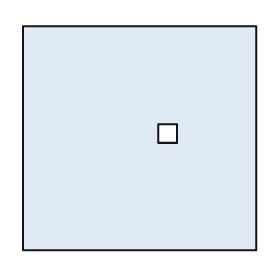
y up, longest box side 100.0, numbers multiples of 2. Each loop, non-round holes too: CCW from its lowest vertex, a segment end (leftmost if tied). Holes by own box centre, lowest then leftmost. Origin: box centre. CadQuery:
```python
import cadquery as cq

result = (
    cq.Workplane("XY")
    .moveTo(-50.0, -48.0)
    .lineTo(50.0, -48.0)
    .lineTo(50.0, 48.0)
    .lineTo(-50.0, 48.0)
    .close()
    .moveTo(8.0, -2.0)
    .lineTo(16.0, -2.0)
    .lineTo(16.0, 6.0)
    .lineTo(8.0, 6.0)
    .close()
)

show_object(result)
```